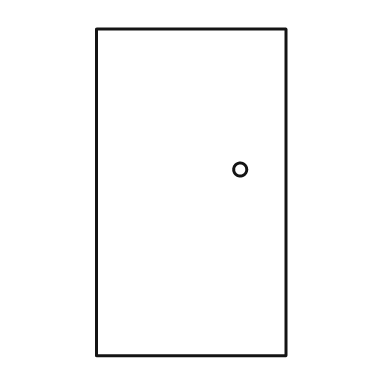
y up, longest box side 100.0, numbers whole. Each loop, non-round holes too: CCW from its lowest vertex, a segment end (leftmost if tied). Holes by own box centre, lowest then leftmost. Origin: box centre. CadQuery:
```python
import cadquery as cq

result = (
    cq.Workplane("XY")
    .moveTo(-29.0, -50.0)
    .lineTo(29.0, -50.0)
    .lineTo(29.0, 50.0)
    .lineTo(-29.0, 50.0)
    .close()
    .moveTo(15.0, 7.0)
    .circle(2.0)
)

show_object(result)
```